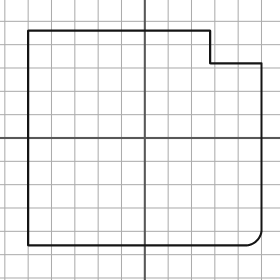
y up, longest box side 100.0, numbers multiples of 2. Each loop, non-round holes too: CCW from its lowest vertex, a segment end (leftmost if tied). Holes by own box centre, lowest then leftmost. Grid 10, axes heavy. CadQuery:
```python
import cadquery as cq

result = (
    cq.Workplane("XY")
    .moveTo(-50.0, -46.0)
    .lineTo(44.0, -46.0)
    .threePointArc((48.0, -44.0), (50.0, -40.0))
    .lineTo(50.0, 32.0)
    .lineTo(28.0, 32.0)
    .lineTo(28.0, 46.0)
    .lineTo(-50.0, 46.0)
    .close()
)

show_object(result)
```